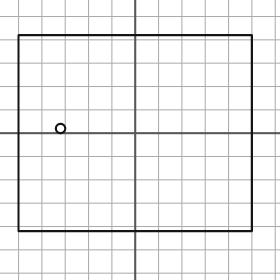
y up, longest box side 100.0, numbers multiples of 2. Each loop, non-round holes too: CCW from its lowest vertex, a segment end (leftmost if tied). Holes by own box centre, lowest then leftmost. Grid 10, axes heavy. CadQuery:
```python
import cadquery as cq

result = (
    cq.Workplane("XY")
    .moveTo(-50.0, -42.0)
    .lineTo(50.0, -42.0)
    .lineTo(50.0, 42.0)
    .lineTo(-50.0, 42.0)
    .close()
    .moveTo(-32.0, 2.0)
    .circle(2.0)
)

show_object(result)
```